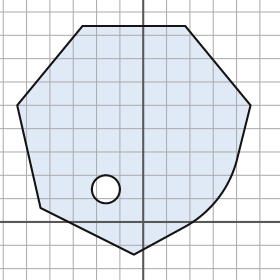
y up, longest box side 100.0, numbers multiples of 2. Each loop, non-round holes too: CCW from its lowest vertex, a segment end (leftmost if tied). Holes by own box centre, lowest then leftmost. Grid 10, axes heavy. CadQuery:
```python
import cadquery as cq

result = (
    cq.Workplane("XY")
    .moveTo(-4.0, -14.0)
    .lineTo(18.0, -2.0)
    .threePointArc((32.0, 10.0), (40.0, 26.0))
    .lineTo(46.0, 50.0)
    .lineTo(18.0, 84.0)
    .lineTo(-26.0, 84.0)
    .lineTo(-54.0, 50.0)
    .lineTo(-44.0, 6.0)
    .close()
    .moveTo(-16.0, 14.0)
    .circle(6.0)
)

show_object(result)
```